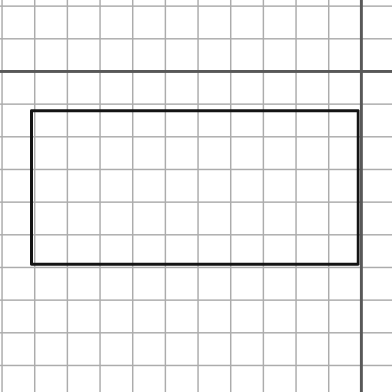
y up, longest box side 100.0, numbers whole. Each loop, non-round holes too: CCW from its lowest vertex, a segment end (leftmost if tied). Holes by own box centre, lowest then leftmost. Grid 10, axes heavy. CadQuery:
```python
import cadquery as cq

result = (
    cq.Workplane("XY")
    .moveTo(-101.0, -59.0)
    .lineTo(-1.0, -59.0)
    .lineTo(-1.0, -12.0)
    .lineTo(-101.0, -12.0)
    .close()
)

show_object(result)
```